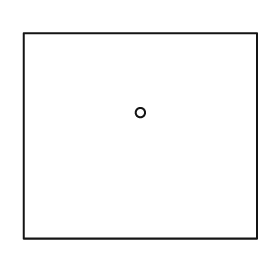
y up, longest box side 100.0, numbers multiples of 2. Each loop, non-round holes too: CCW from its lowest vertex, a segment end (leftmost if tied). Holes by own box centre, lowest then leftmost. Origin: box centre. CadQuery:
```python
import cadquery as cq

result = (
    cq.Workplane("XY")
    .moveTo(-50.0, -44.0)
    .lineTo(50.0, -44.0)
    .lineTo(50.0, 44.0)
    .lineTo(-50.0, 44.0)
    .close()
    .moveTo(0.0, 10.0)
    .circle(2.0)
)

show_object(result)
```